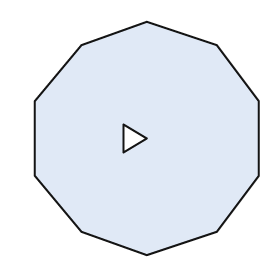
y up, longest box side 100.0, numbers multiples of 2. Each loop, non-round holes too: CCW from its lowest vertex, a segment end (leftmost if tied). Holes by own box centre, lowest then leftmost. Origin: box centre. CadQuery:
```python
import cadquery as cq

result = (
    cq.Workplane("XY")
    .moveTo(0.0, -50.0)
    .lineTo(30.0, -40.0)
    .lineTo(48.0, -16.0)
    .lineTo(48.0, 16.0)
    .lineTo(30.0, 40.0)
    .lineTo(0.0, 50.0)
    .lineTo(-28.0, 40.0)
    .lineTo(-48.0, 16.0)
    .lineTo(-48.0, -16.0)
    .lineTo(-28.0, -40.0)
    .close()
    .moveTo(-10.0, -6.0)
    .lineTo(0.0, 0.0)
    .lineTo(-10.0, 6.0)
    .close()
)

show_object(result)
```